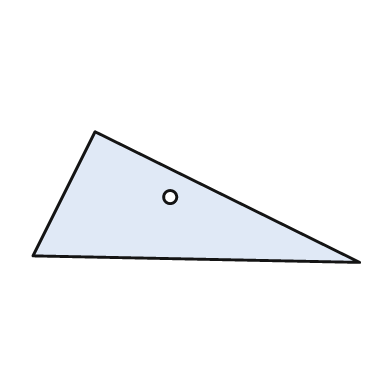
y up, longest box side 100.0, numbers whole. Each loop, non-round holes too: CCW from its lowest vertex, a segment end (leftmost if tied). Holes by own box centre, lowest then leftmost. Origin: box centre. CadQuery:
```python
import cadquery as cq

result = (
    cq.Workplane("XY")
    .moveTo(50.0, -20.0)
    .lineTo(-31.0, 20.0)
    .lineTo(-50.0, -18.0)
    .close()
    .moveTo(-8.0, 0.0)
    .circle(2.0)
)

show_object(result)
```